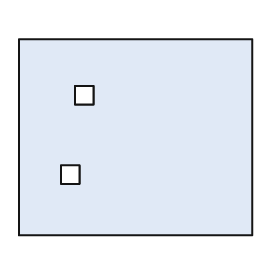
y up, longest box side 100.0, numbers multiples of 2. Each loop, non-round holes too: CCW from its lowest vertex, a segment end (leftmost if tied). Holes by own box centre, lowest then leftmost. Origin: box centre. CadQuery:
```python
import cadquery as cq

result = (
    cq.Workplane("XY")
    .moveTo(-50.0, -42.0)
    .lineTo(50.0, -42.0)
    .lineTo(50.0, 42.0)
    .lineTo(-50.0, 42.0)
    .close()
    .moveTo(-32.0, -20.0)
    .lineTo(-24.0, -20.0)
    .lineTo(-24.0, -12.0)
    .lineTo(-32.0, -12.0)
    .close()
    .moveTo(-26.0, 14.0)
    .lineTo(-18.0, 14.0)
    .lineTo(-18.0, 22.0)
    .lineTo(-26.0, 22.0)
    .close()
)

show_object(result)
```